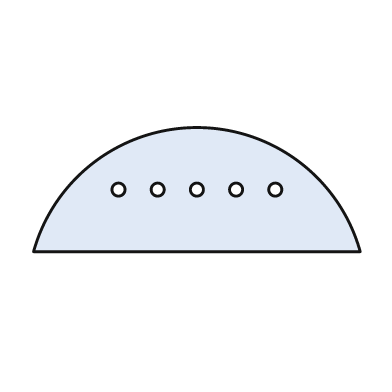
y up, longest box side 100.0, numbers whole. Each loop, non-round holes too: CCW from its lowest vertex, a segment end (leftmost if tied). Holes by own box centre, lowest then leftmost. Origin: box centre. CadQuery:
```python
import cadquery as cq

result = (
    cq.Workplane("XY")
    .moveTo(-50.0, -19.0)
    .lineTo(50.0, -19.0)
    .threePointArc((0.0, 19.0), (-50.0, -19.0))
    .close()
    .moveTo(-24.0, 0.0)
    .circle(2.0)
    .moveTo(-12.0, 0.0)
    .circle(2.0)
    .moveTo(0.0, 0.0)
    .circle(2.0)
    .moveTo(12.0, 0.0)
    .circle(2.0)
    .moveTo(24.0, 0.0)
    .circle(2.0)
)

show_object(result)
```